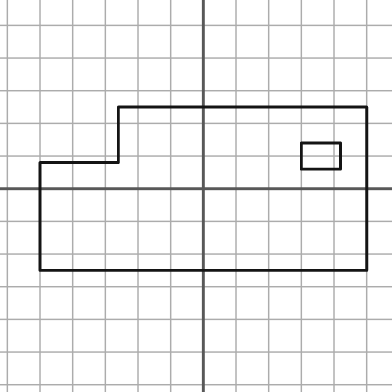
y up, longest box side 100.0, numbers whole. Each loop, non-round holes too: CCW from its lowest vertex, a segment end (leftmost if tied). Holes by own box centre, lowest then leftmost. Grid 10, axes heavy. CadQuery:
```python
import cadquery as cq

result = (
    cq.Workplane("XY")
    .moveTo(-50.0, -25.0)
    .lineTo(50.0, -25.0)
    .lineTo(50.0, 25.0)
    .lineTo(-26.0, 25.0)
    .lineTo(-26.0, 8.0)
    .lineTo(-50.0, 8.0)
    .close()
    .moveTo(30.0, 6.0)
    .lineTo(42.0, 6.0)
    .lineTo(42.0, 14.0)
    .lineTo(30.0, 14.0)
    .close()
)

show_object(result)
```